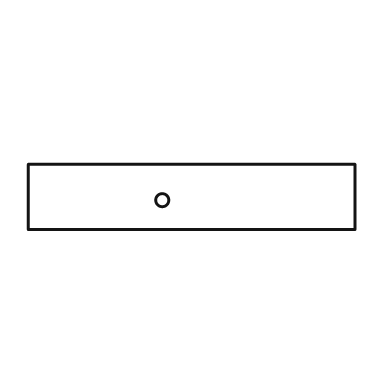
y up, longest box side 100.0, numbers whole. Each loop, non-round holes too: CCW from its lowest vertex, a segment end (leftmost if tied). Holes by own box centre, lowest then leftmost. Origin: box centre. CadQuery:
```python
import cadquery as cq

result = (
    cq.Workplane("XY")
    .moveTo(-50.0, -10.0)
    .lineTo(50.0, -10.0)
    .lineTo(50.0, 10.0)
    .lineTo(-50.0, 10.0)
    .close()
    .moveTo(-9.0, -1.0)
    .circle(2.0)
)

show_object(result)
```